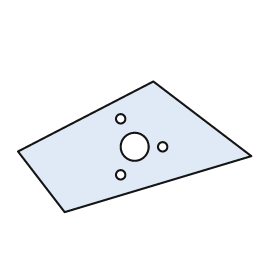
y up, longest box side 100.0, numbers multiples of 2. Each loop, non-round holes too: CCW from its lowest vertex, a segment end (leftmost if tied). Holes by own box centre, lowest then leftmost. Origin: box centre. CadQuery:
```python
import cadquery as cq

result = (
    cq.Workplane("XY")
    .moveTo(-30.0, -28.0)
    .lineTo(50.0, -4.0)
    .lineTo(8.0, 28.0)
    .lineTo(-50.0, -2.0)
    .close()
    .moveTo(-6.0, -12.0)
    .circle(2.0)
    .moveTo(0.0, 0.0)
    .circle(6.0)
    .moveTo(12.0, 0.0)
    .circle(2.0)
    .moveTo(-6.0, 12.0)
    .circle(2.0)
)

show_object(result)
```